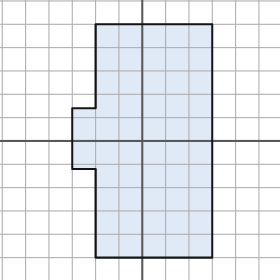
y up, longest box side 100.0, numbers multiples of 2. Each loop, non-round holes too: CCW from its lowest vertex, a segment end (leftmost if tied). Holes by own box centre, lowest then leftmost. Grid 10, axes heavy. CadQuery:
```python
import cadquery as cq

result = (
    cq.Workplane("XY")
    .moveTo(-20.0, -50.0)
    .lineTo(30.0, -50.0)
    .lineTo(30.0, 50.0)
    .lineTo(-20.0, 50.0)
    .lineTo(-20.0, 14.0)
    .lineTo(-30.0, 14.0)
    .lineTo(-30.0, -12.0)
    .lineTo(-20.0, -12.0)
    .close()
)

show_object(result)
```